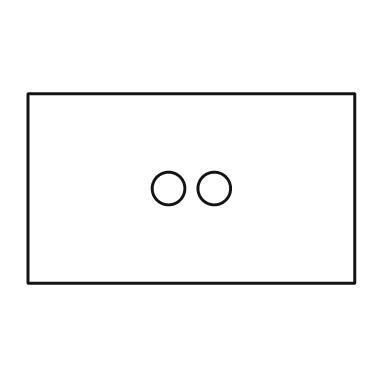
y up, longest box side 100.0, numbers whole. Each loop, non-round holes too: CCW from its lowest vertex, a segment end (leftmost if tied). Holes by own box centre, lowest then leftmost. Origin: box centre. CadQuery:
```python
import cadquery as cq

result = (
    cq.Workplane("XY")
    .moveTo(-50.0, -29.0)
    .lineTo(50.0, -29.0)
    .lineTo(50.0, 29.0)
    .lineTo(-50.0, 29.0)
    .close()
    .moveTo(-7.0, 0.0)
    .circle(5.0)
    .moveTo(7.0, 0.0)
    .circle(5.0)
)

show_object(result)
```